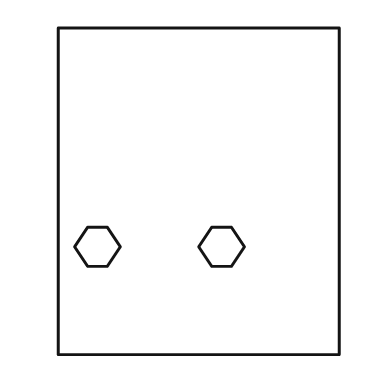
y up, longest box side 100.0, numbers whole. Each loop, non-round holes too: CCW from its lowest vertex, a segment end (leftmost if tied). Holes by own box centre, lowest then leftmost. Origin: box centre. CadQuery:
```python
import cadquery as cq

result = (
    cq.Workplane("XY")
    .moveTo(-43.0, -50.0)
    .lineTo(43.0, -50.0)
    .lineTo(43.0, 50.0)
    .lineTo(-43.0, 50.0)
    .close()
    .moveTo(-34.0, -23.0)
    .lineTo(-28.0, -23.0)
    .lineTo(-24.0, -17.0)
    .lineTo(-28.0, -11.0)
    .lineTo(-34.0, -11.0)
    .lineTo(-38.0, -17.0)
    .close()
    .moveTo(4.0, -23.0)
    .lineTo(10.0, -23.0)
    .lineTo(14.0, -17.0)
    .lineTo(10.0, -11.0)
    .lineTo(4.0, -11.0)
    .lineTo(0.0, -17.0)
    .close()
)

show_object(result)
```